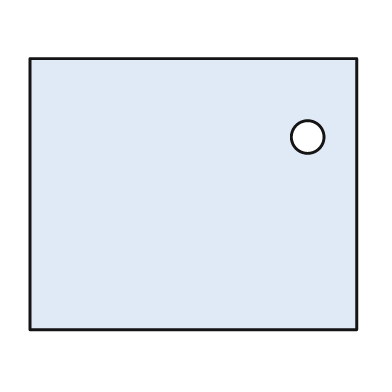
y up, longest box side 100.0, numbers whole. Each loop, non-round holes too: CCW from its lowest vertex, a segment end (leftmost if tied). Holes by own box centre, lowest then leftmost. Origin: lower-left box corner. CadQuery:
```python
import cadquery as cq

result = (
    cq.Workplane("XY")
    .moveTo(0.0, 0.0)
    .lineTo(100.0, 0.0)
    .lineTo(100.0, 83.0)
    .lineTo(0.0, 83.0)
    .close()
    .moveTo(85.0, 59.0)
    .circle(5.0)
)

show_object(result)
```